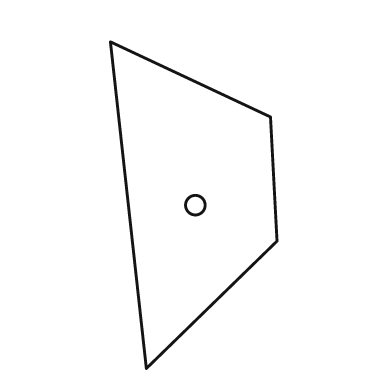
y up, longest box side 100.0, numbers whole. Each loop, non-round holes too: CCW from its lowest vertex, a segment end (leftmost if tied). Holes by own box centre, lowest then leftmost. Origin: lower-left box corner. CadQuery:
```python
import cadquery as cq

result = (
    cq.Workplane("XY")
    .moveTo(11.0, 0.0)
    .lineTo(51.0, 39.0)
    .lineTo(49.0, 77.0)
    .lineTo(0.0, 100.0)
    .close()
    .moveTo(26.0, 50.0)
    .circle(3.0)
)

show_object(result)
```